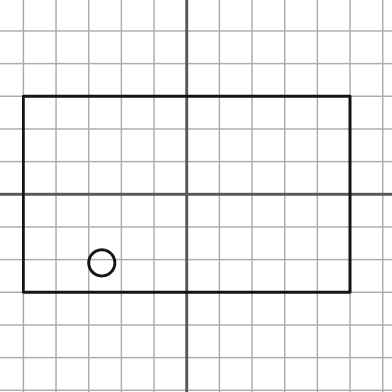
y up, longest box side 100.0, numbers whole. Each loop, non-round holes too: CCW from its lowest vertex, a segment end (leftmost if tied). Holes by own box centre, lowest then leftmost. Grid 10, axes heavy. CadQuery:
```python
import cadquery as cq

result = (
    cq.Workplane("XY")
    .moveTo(-50.0, -30.0)
    .lineTo(50.0, -30.0)
    .lineTo(50.0, 30.0)
    .lineTo(-50.0, 30.0)
    .close()
    .moveTo(-26.0, -21.0)
    .circle(4.0)
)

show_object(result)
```